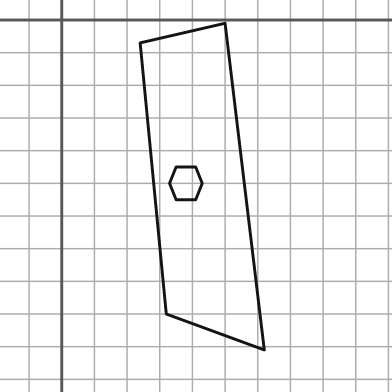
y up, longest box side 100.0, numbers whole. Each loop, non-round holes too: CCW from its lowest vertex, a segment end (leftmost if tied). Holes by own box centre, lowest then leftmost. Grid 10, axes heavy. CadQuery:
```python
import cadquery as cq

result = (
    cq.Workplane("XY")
    .moveTo(62.0, -101.0)
    .lineTo(50.0, -1.0)
    .lineTo(24.0, -7.0)
    .lineTo(32.0, -90.0)
    .close()
    .moveTo(35.0, -55.0)
    .lineTo(41.0, -55.0)
    .lineTo(43.0, -50.0)
    .lineTo(41.0, -45.0)
    .lineTo(35.0, -45.0)
    .lineTo(33.0, -50.0)
    .close()
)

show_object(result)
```